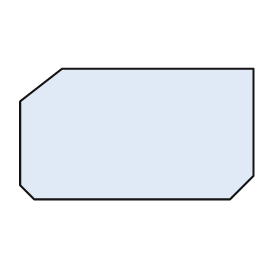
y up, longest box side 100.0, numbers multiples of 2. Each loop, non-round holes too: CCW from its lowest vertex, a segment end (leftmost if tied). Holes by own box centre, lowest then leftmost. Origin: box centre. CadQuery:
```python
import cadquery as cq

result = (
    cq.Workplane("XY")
    .moveTo(-44.0, -28.0)
    .lineTo(40.0, -28.0)
    .lineTo(50.0, -18.0)
    .lineTo(50.0, 28.0)
    .lineTo(-32.0, 28.0)
    .lineTo(-50.0, 14.0)
    .lineTo(-50.0, -22.0)
    .close()
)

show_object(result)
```